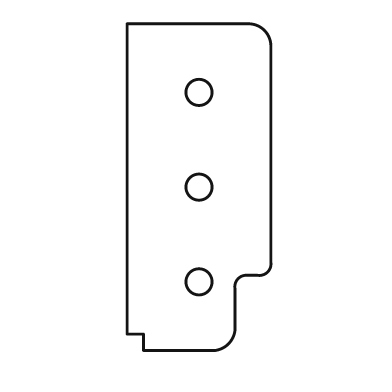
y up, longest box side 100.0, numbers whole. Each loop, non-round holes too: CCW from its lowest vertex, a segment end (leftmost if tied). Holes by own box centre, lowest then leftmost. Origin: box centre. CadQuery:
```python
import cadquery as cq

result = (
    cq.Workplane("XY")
    .moveTo(-17.0, -50.0)
    .lineTo(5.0, -50.0)
    .threePointArc((9.0, -48.0), (11.0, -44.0))
    .lineTo(11.0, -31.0)
    .threePointArc((12.0, -28.0), (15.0, -27.0))
    .lineTo(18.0, -27.0)
    .threePointArc((21.0, -26.0), (22.0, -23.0))
    .lineTo(22.0, 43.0)
    .threePointArc((20.0, 48.0), (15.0, 50.0))
    .lineTo(-22.0, 50.0)
    .lineTo(-22.0, -45.0)
    .lineTo(-17.0, -45.0)
    .close()
    .moveTo(0.0, -29.0)
    .circle(4.0)
    .moveTo(0.0, 0.0)
    .circle(4.0)
    .moveTo(0.0, 29.0)
    .circle(4.0)
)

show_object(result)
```